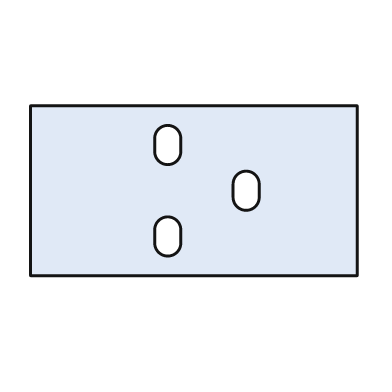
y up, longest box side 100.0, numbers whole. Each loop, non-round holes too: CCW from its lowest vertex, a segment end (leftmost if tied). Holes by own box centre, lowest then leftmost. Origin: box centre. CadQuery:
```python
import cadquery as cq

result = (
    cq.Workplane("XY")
    .moveTo(-50.0, -26.0)
    .lineTo(50.0, -26.0)
    .lineTo(50.0, 26.0)
    .lineTo(-50.0, 26.0)
    .close()
    .moveTo(-12.0, -16.0)
    .threePointArc((-8.0, -20.0), (-4.0, -16.0))
    .lineTo(-4.0, -12.0)
    .threePointArc((-8.0, -8.0), (-12.0, -12.0))
    .close()
    .moveTo(12.0, -2.0)
    .threePointArc((16.0, -6.0), (20.0, -2.0))
    .lineTo(20.0, 2.0)
    .threePointArc((16.0, 6.0), (12.0, 2.0))
    .close()
    .moveTo(-12.0, 12.0)
    .threePointArc((-8.0, 8.0), (-4.0, 12.0))
    .lineTo(-4.0, 16.0)
    .threePointArc((-8.0, 20.0), (-12.0, 16.0))
    .close()
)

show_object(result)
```